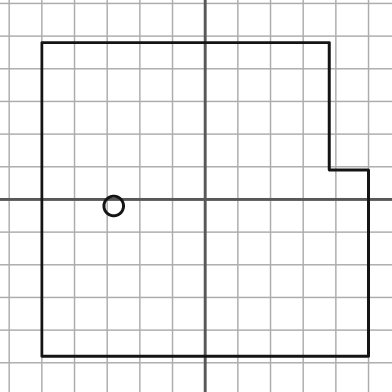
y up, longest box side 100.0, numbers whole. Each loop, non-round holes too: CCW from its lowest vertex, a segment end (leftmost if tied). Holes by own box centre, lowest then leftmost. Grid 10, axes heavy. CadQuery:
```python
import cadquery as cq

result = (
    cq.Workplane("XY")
    .moveTo(-50.0, -48.0)
    .lineTo(50.0, -48.0)
    .lineTo(50.0, 9.0)
    .lineTo(38.0, 9.0)
    .lineTo(38.0, 48.0)
    .lineTo(-50.0, 48.0)
    .close()
    .moveTo(-28.0, -2.0)
    .circle(3.0)
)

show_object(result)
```